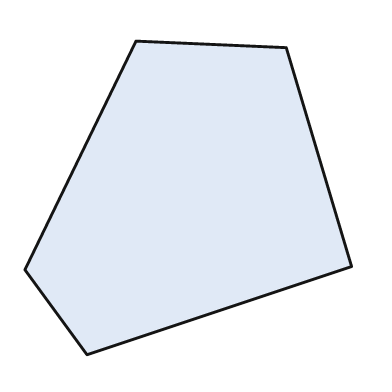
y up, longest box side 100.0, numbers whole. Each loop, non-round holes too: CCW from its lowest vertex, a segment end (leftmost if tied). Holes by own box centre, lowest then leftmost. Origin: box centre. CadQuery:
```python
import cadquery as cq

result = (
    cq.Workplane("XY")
    .moveTo(-31.0, -48.0)
    .lineTo(50.0, -21.0)
    .lineTo(30.0, 46.0)
    .lineTo(-16.0, 48.0)
    .lineTo(-50.0, -22.0)
    .close()
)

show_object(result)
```